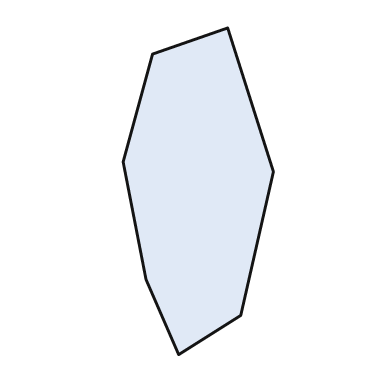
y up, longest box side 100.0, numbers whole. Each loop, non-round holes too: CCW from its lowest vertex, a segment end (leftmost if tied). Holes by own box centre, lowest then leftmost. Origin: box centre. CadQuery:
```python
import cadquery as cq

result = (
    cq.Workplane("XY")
    .moveTo(-6.0, -50.0)
    .lineTo(13.0, -38.0)
    .lineTo(23.0, 6.0)
    .lineTo(9.0, 50.0)
    .lineTo(-14.0, 42.0)
    .lineTo(-23.0, 9.0)
    .lineTo(-16.0, -27.0)
    .close()
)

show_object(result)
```